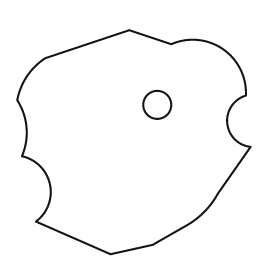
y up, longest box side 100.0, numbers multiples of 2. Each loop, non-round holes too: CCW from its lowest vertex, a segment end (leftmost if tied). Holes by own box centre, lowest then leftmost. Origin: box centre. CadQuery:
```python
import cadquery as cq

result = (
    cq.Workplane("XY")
    .moveTo(-10.0, -48.0)
    .lineTo(8.0, -44.0)
    .lineTo(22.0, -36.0)
    .threePointArc((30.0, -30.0), (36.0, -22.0))
    .lineTo(50.0, -2.0)
    .threePointArc((40.0, 8.0), (48.0, 20.0))
    .threePointArc((38.0, 40.0), (16.0, 42.0))
    .lineTo(-2.0, 48.0)
    .lineTo(-38.0, 36.0)
    .threePointArc((-46.0, 28.0), (-50.0, 18.0))
    .threePointArc((-46.0, 6.0), (-48.0, -6.0))
    .threePointArc((-36.0, -18.0), (-42.0, -34.0))
    .close()
    .moveTo(10.0, 16.0)
    .circle(6.0)
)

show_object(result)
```